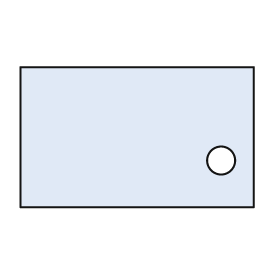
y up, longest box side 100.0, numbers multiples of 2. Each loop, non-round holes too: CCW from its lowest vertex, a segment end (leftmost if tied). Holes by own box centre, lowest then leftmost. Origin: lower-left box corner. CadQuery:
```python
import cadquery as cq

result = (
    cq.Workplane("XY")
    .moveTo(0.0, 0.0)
    .lineTo(100.0, 0.0)
    .lineTo(100.0, 60.0)
    .lineTo(0.0, 60.0)
    .close()
    .moveTo(86.0, 20.0)
    .circle(6.0)
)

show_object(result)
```